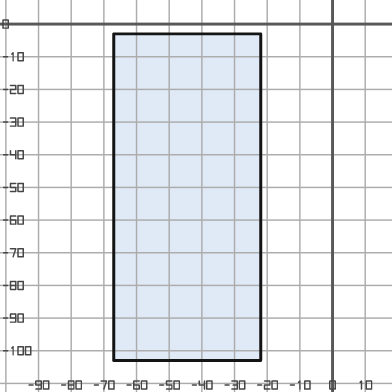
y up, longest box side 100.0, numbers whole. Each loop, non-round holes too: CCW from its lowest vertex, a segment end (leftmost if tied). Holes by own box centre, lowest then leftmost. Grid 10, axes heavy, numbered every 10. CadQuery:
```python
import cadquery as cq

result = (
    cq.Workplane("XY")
    .moveTo(-67.0, -103.0)
    .lineTo(-22.0, -103.0)
    .lineTo(-22.0, -3.0)
    .lineTo(-67.0, -3.0)
    .close()
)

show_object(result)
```